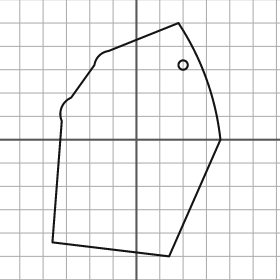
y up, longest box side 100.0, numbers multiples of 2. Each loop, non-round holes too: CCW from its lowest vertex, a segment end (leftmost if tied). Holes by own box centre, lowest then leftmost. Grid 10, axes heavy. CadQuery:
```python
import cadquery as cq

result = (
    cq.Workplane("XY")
    .moveTo(14.0, -50.0)
    .lineTo(36.0, 0.0)
    .threePointArc((30.0, 26.0), (18.0, 50.0))
    .lineTo(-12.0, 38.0)
    .threePointArc((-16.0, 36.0), (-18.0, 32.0))
    .lineTo(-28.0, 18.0)
    .threePointArc((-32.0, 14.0), (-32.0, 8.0))
    .lineTo(-36.0, -44.0)
    .close()
    .moveTo(20.0, 32.0)
    .circle(2.0)
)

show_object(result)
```